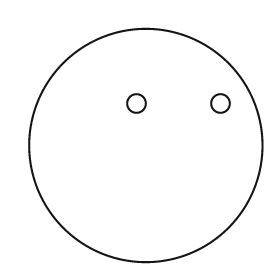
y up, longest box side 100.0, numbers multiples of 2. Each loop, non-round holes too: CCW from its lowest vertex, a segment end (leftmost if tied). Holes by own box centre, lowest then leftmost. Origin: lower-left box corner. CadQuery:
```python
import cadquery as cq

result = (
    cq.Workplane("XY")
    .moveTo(50.0, 50.0)
    .circle(50.0)
    .moveTo(46.0, 68.0)
    .circle(4.0)
    .moveTo(82.0, 68.0)
    .circle(4.0)
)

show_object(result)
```